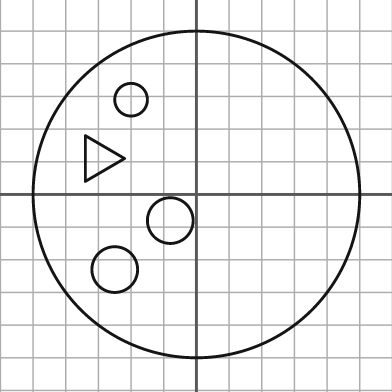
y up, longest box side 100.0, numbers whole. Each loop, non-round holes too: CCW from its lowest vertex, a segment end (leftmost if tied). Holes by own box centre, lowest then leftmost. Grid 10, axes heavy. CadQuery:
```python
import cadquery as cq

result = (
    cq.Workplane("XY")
    .moveTo(0.0, 0.0)
    .circle(50.0)
    .moveTo(-25.0, -23.0)
    .circle(7.0)
    .moveTo(-8.0, -8.0)
    .circle(7.0)
    .moveTo(-34.0, 4.0)
    .lineTo(-22.0, 11.0)
    .lineTo(-34.0, 18.0)
    .close()
    .moveTo(-20.0, 29.0)
    .circle(5.0)
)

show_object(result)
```